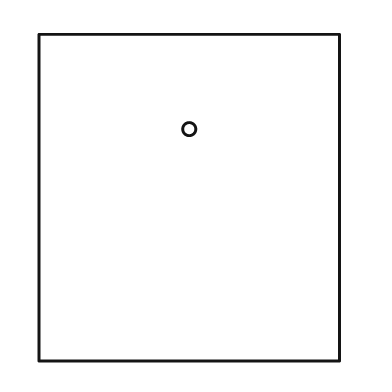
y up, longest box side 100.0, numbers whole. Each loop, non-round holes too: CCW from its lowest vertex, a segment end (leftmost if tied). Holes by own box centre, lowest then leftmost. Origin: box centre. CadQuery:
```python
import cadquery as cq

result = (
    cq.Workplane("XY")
    .moveTo(-46.0, -50.0)
    .lineTo(46.0, -50.0)
    .lineTo(46.0, 50.0)
    .lineTo(-46.0, 50.0)
    .close()
    .moveTo(0.0, 21.0)
    .circle(2.0)
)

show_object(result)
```